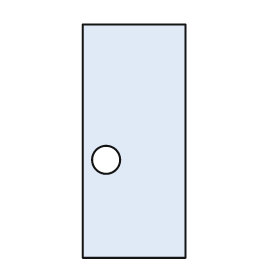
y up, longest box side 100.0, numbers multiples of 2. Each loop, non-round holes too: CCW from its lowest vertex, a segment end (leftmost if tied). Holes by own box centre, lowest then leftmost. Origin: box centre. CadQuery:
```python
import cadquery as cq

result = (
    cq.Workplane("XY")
    .moveTo(-22.0, -50.0)
    .lineTo(22.0, -50.0)
    .lineTo(22.0, 50.0)
    .lineTo(-22.0, 50.0)
    .close()
    .moveTo(-12.0, -8.0)
    .circle(6.0)
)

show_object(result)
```